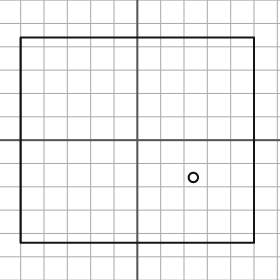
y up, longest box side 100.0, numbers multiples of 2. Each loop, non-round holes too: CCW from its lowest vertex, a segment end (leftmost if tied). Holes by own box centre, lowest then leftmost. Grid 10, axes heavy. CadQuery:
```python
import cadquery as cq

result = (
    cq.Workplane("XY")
    .moveTo(-50.0, -44.0)
    .lineTo(50.0, -44.0)
    .lineTo(50.0, 44.0)
    .lineTo(-50.0, 44.0)
    .close()
    .moveTo(24.0, -16.0)
    .circle(2.0)
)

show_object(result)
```